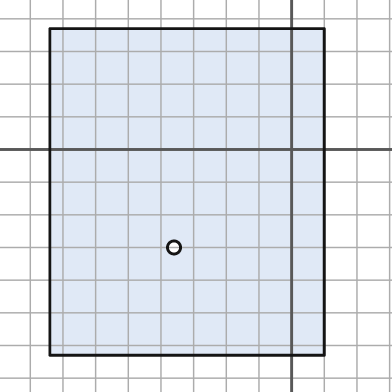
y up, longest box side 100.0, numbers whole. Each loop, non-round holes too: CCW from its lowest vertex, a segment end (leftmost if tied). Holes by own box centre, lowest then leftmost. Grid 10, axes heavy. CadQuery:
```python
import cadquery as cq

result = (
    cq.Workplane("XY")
    .moveTo(-74.0, -63.0)
    .lineTo(10.0, -63.0)
    .lineTo(10.0, 37.0)
    .lineTo(-74.0, 37.0)
    .close()
    .moveTo(-36.0, -30.0)
    .circle(2.0)
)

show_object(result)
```